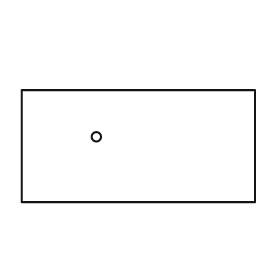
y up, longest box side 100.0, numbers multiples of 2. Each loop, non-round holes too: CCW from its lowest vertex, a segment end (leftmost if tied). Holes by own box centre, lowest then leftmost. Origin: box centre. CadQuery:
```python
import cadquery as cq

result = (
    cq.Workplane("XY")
    .moveTo(-50.0, -24.0)
    .lineTo(50.0, -24.0)
    .lineTo(50.0, 24.0)
    .lineTo(-50.0, 24.0)
    .close()
    .moveTo(-18.0, 4.0)
    .circle(2.0)
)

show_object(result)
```